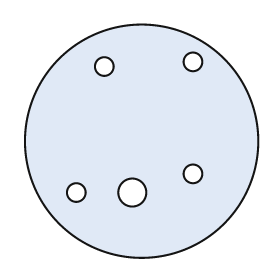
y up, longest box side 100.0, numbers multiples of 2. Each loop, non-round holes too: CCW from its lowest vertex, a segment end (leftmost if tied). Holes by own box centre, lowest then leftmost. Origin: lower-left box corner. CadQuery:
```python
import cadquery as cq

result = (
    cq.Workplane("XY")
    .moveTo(50.0, 50.0)
    .circle(50.0)
    .moveTo(22.0, 28.0)
    .circle(4.0)
    .moveTo(46.0, 28.0)
    .circle(6.0)
    .moveTo(72.0, 36.0)
    .circle(4.0)
    .moveTo(34.0, 82.0)
    .circle(4.0)
    .moveTo(72.0, 84.0)
    .circle(4.0)
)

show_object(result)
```